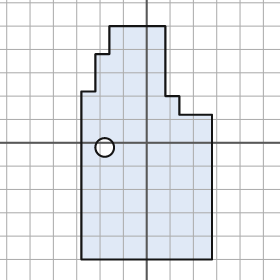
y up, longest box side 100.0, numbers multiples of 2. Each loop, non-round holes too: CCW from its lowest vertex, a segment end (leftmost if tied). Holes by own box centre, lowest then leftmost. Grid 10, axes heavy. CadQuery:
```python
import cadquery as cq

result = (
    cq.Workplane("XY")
    .moveTo(-28.0, -50.0)
    .lineTo(28.0, -50.0)
    .lineTo(28.0, 12.0)
    .lineTo(14.0, 12.0)
    .lineTo(14.0, 20.0)
    .lineTo(8.0, 20.0)
    .lineTo(8.0, 50.0)
    .lineTo(-16.0, 50.0)
    .lineTo(-16.0, 38.0)
    .lineTo(-22.0, 38.0)
    .lineTo(-22.0, 22.0)
    .lineTo(-28.0, 22.0)
    .close()
    .moveTo(-18.0, -2.0)
    .circle(4.0)
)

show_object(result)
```